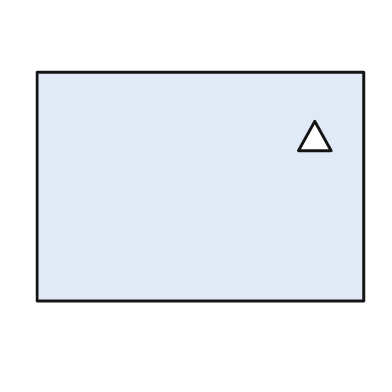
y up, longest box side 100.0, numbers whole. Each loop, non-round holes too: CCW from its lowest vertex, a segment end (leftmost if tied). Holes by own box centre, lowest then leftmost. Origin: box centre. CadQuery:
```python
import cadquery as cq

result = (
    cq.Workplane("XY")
    .moveTo(-50.0, -35.0)
    .lineTo(50.0, -35.0)
    .lineTo(50.0, 35.0)
    .lineTo(-50.0, 35.0)
    .close()
    .moveTo(30.0, 11.0)
    .lineTo(40.0, 11.0)
    .lineTo(35.0, 20.0)
    .close()
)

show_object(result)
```